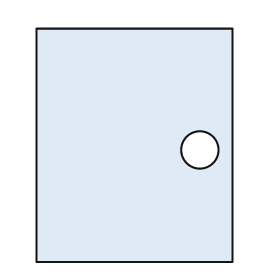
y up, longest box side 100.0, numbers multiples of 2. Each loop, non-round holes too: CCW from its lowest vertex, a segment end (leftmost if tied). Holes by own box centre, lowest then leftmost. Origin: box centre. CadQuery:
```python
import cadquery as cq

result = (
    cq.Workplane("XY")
    .moveTo(-42.0, -50.0)
    .lineTo(42.0, -50.0)
    .lineTo(42.0, 50.0)
    .lineTo(-42.0, 50.0)
    .close()
    .moveTo(28.0, -2.0)
    .circle(8.0)
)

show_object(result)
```